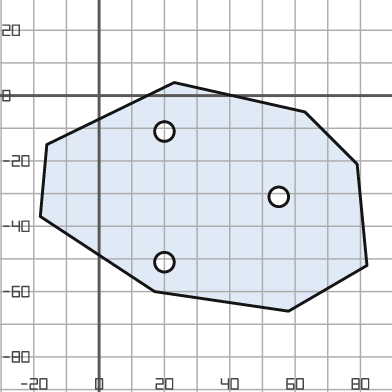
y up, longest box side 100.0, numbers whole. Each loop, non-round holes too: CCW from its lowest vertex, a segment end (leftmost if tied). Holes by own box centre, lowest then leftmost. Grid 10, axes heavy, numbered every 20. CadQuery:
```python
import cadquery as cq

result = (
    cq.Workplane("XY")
    .moveTo(58.0, -66.0)
    .lineTo(82.0, -52.0)
    .lineTo(79.0, -21.0)
    .lineTo(63.0, -5.0)
    .lineTo(23.0, 4.0)
    .lineTo(-16.0, -15.0)
    .lineTo(-18.0, -37.0)
    .lineTo(17.0, -60.0)
    .close()
    .moveTo(20.0, -51.0)
    .circle(3.0)
    .moveTo(55.0, -31.0)
    .circle(3.0)
    .moveTo(20.0, -11.0)
    .circle(3.0)
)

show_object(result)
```